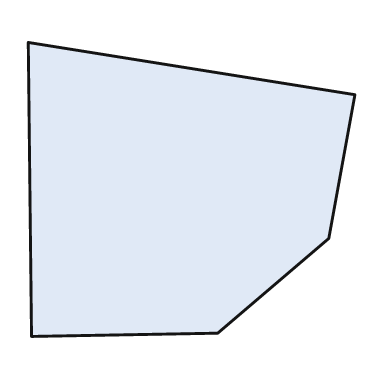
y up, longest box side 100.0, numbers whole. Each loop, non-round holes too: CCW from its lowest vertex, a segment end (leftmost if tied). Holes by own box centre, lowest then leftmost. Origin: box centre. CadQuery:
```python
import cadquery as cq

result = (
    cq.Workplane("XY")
    .moveTo(-49.0, -45.0)
    .lineTo(8.0, -44.0)
    .lineTo(42.0, -15.0)
    .lineTo(50.0, 29.0)
    .lineTo(-50.0, 45.0)
    .close()
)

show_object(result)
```